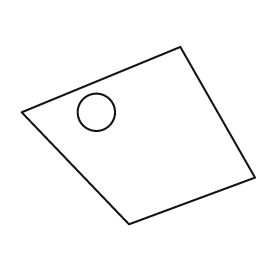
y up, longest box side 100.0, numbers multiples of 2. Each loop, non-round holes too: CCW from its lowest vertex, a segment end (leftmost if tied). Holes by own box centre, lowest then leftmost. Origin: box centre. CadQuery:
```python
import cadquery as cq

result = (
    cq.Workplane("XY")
    .moveTo(-4.0, -38.0)
    .lineTo(50.0, -18.0)
    .lineTo(18.0, 38.0)
    .lineTo(-50.0, 10.0)
    .close()
    .moveTo(-18.0, 10.0)
    .circle(8.0)
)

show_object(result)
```